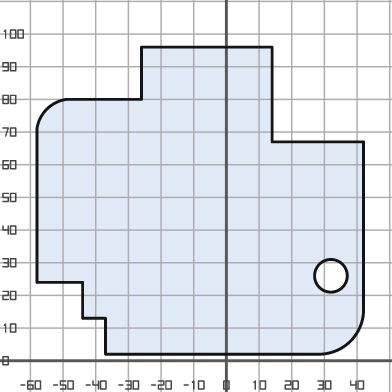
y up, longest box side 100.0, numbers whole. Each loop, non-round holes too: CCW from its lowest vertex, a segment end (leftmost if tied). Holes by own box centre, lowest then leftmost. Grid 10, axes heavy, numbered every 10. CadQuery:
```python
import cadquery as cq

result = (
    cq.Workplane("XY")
    .moveTo(-37.0, 2.0)
    .lineTo(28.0, 2.0)
    .threePointArc((38.0, 6.0), (42.0, 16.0))
    .lineTo(42.0, 67.0)
    .lineTo(14.0, 67.0)
    .lineTo(14.0, 96.0)
    .lineTo(-26.0, 96.0)
    .lineTo(-26.0, 80.0)
    .lineTo(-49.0, 80.0)
    .threePointArc((-55.0, 77.0), (-58.0, 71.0))
    .lineTo(-58.0, 24.0)
    .lineTo(-44.0, 24.0)
    .lineTo(-44.0, 13.0)
    .lineTo(-37.0, 13.0)
    .close()
    .moveTo(32.0, 26.0)
    .circle(5.0)
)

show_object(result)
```